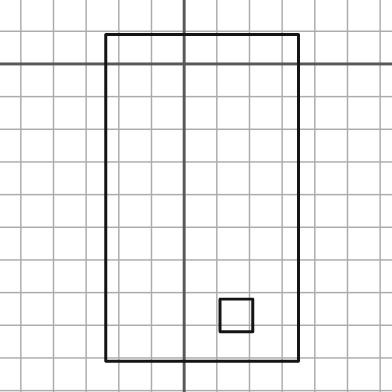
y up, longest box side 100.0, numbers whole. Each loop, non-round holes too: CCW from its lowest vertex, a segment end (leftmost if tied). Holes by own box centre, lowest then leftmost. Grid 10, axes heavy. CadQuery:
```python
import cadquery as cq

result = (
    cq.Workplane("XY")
    .moveTo(-24.0, -91.0)
    .lineTo(35.0, -91.0)
    .lineTo(35.0, 9.0)
    .lineTo(-24.0, 9.0)
    .close()
    .moveTo(11.0, -82.0)
    .lineTo(21.0, -82.0)
    .lineTo(21.0, -72.0)
    .lineTo(11.0, -72.0)
    .close()
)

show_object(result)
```